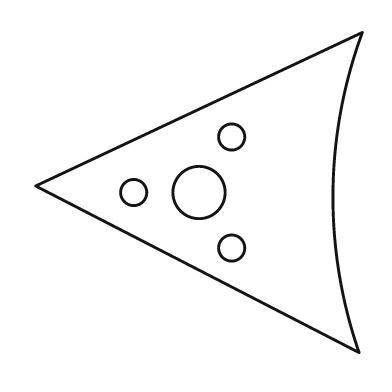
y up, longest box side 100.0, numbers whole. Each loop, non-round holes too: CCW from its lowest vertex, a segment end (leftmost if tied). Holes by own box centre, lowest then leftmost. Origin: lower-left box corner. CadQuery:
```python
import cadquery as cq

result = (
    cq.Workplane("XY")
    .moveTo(99.0, 0.0)
    .threePointArc((91.0, 49.0), (100.0, 98.0))
    .lineTo(0.0, 51.0)
    .close()
    .moveTo(60.0, 32.0)
    .circle(4.0)
    .moveTo(30.0, 49.0)
    .circle(4.0)
    .moveTo(50.0, 49.0)
    .circle(8.0)
    .moveTo(60.0, 66.0)
    .circle(4.0)
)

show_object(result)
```